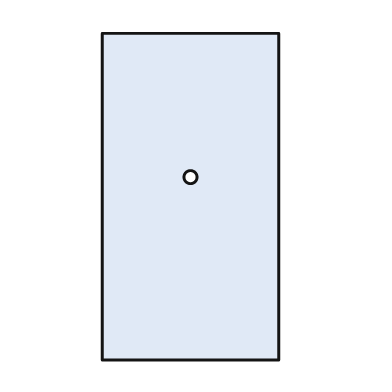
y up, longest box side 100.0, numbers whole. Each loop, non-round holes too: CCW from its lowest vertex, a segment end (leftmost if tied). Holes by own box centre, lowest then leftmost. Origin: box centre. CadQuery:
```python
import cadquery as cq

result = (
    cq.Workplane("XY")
    .moveTo(-27.0, -50.0)
    .lineTo(27.0, -50.0)
    .lineTo(27.0, 50.0)
    .lineTo(-27.0, 50.0)
    .close()
    .moveTo(0.0, 6.0)
    .circle(2.0)
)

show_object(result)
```